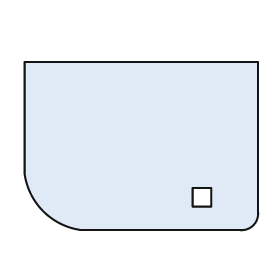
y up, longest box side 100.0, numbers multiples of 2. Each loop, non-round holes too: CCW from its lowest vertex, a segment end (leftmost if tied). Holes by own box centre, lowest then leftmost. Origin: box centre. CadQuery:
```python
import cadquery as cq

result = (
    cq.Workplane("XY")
    .moveTo(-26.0, -36.0)
    .lineTo(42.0, -36.0)
    .threePointArc((48.0, -34.0), (50.0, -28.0))
    .lineTo(50.0, 36.0)
    .lineTo(-50.0, 36.0)
    .lineTo(-50.0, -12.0)
    .threePointArc((-42.0, -28.0), (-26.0, -36.0))
    .close()
    .moveTo(22.0, -26.0)
    .lineTo(30.0, -26.0)
    .lineTo(30.0, -18.0)
    .lineTo(22.0, -18.0)
    .close()
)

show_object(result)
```